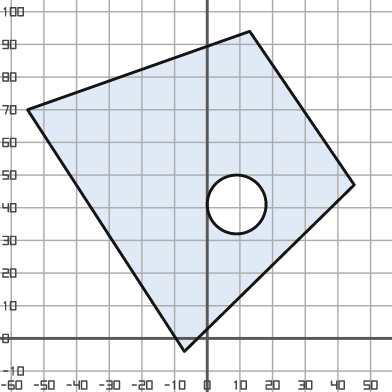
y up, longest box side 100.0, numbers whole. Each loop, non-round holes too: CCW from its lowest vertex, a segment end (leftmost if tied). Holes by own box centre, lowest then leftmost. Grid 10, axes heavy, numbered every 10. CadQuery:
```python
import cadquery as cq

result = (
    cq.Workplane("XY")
    .moveTo(-7.0, -4.0)
    .lineTo(45.0, 47.0)
    .lineTo(13.0, 94.0)
    .lineTo(-55.0, 70.0)
    .close()
    .moveTo(9.0, 41.0)
    .circle(9.0)
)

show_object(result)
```